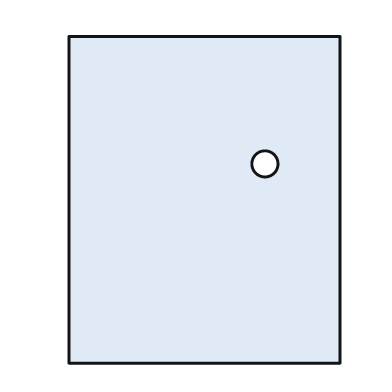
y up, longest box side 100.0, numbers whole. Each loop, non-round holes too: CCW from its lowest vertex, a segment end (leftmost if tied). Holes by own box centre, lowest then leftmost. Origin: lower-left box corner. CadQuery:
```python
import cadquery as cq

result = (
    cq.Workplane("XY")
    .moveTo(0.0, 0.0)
    .lineTo(83.0, 0.0)
    .lineTo(83.0, 100.0)
    .lineTo(0.0, 100.0)
    .close()
    .moveTo(60.0, 61.0)
    .circle(4.0)
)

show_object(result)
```